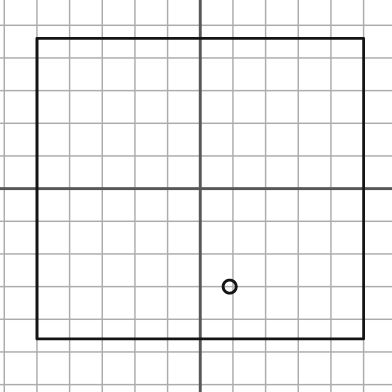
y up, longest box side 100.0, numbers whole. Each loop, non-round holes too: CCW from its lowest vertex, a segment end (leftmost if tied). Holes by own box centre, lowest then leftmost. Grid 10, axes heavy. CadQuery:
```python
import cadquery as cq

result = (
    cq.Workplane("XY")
    .moveTo(-50.0, -46.0)
    .lineTo(50.0, -46.0)
    .lineTo(50.0, 46.0)
    .lineTo(-50.0, 46.0)
    .close()
    .moveTo(9.0, -30.0)
    .circle(2.0)
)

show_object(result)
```